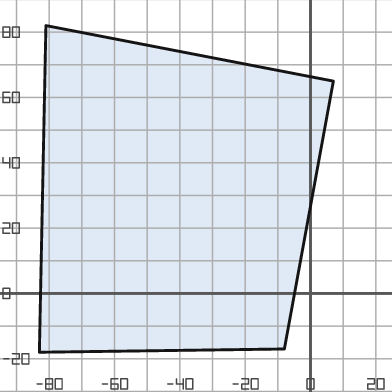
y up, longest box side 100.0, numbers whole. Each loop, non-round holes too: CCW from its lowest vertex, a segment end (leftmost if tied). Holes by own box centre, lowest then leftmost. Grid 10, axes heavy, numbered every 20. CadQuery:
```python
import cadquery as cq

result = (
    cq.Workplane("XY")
    .moveTo(-83.0, -18.0)
    .lineTo(-8.0, -17.0)
    .lineTo(7.0, 65.0)
    .lineTo(-81.0, 82.0)
    .close()
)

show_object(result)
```